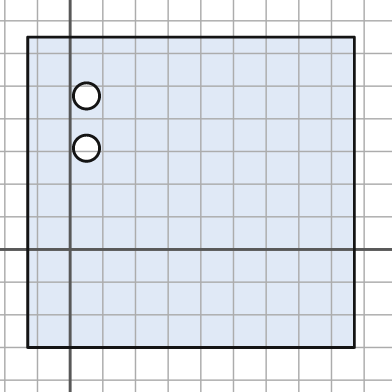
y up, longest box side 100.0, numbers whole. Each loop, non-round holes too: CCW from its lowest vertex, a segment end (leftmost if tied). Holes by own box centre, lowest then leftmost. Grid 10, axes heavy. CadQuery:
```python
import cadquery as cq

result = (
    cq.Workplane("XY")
    .moveTo(-13.0, -30.0)
    .lineTo(87.0, -30.0)
    .lineTo(87.0, 65.0)
    .lineTo(-13.0, 65.0)
    .close()
    .moveTo(5.0, 31.0)
    .circle(4.0)
    .moveTo(5.0, 47.0)
    .circle(4.0)
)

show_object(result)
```